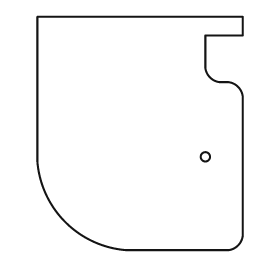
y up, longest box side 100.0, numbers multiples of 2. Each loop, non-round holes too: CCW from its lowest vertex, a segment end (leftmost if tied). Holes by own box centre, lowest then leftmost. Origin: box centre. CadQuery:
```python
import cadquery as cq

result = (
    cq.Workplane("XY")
    .moveTo(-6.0, -50.0)
    .lineTo(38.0, -50.0)
    .threePointArc((42.0, -48.0), (44.0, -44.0))
    .lineTo(44.0, 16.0)
    .threePointArc((42.0, 20.0), (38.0, 22.0))
    .lineTo(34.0, 22.0)
    .threePointArc((30.0, 24.0), (28.0, 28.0))
    .lineTo(28.0, 42.0)
    .lineTo(44.0, 42.0)
    .lineTo(44.0, 50.0)
    .lineTo(-44.0, 50.0)
    .lineTo(-44.0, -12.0)
    .threePointArc((-32.0, -38.0), (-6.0, -50.0))
    .close()
    .moveTo(28.0, -10.0)
    .circle(2.0)
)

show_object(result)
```